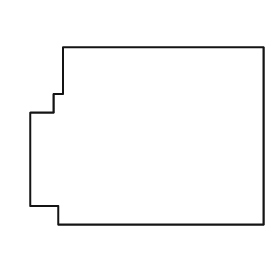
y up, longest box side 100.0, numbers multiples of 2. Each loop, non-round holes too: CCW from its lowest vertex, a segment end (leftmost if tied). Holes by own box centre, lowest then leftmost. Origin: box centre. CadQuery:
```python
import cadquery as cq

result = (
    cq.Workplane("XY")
    .moveTo(-38.0, -38.0)
    .lineTo(50.0, -38.0)
    .lineTo(50.0, 38.0)
    .lineTo(-36.0, 38.0)
    .lineTo(-36.0, 18.0)
    .lineTo(-40.0, 18.0)
    .lineTo(-40.0, 10.0)
    .lineTo(-50.0, 10.0)
    .lineTo(-50.0, -30.0)
    .lineTo(-38.0, -30.0)
    .close()
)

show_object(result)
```